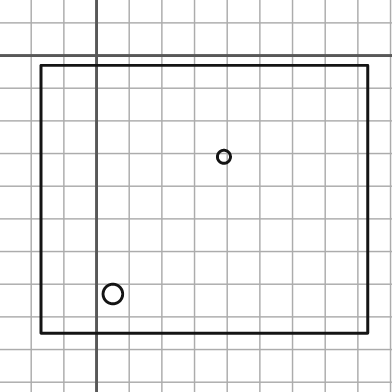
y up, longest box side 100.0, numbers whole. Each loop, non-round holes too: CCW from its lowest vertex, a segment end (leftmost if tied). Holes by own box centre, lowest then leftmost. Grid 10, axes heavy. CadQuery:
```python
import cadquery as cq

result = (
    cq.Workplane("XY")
    .moveTo(-17.0, -85.0)
    .lineTo(83.0, -85.0)
    .lineTo(83.0, -3.0)
    .lineTo(-17.0, -3.0)
    .close()
    .moveTo(5.0, -73.0)
    .circle(3.0)
    .moveTo(39.0, -31.0)
    .circle(2.0)
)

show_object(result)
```